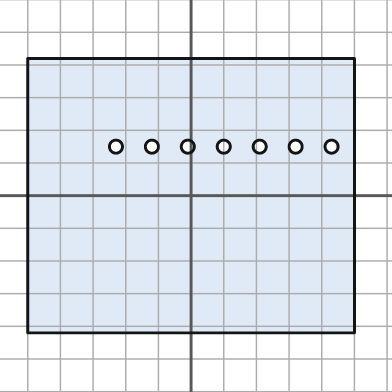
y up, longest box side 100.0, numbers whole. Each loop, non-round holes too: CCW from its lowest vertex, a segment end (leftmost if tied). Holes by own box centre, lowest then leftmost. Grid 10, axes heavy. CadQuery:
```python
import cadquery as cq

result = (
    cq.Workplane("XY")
    .moveTo(-50.0, -42.0)
    .lineTo(50.0, -42.0)
    .lineTo(50.0, 42.0)
    .lineTo(-50.0, 42.0)
    .close()
    .moveTo(-23.0, 15.0)
    .circle(2.0)
    .moveTo(-12.0, 15.0)
    .circle(2.0)
    .moveTo(-1.0, 15.0)
    .circle(2.0)
    .moveTo(10.0, 15.0)
    .circle(2.0)
    .moveTo(21.0, 15.0)
    .circle(2.0)
    .moveTo(32.0, 15.0)
    .circle(2.0)
    .moveTo(43.0, 15.0)
    .circle(2.0)
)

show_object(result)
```